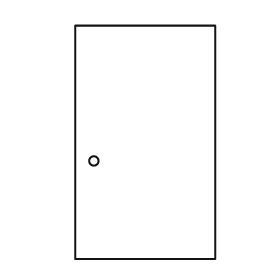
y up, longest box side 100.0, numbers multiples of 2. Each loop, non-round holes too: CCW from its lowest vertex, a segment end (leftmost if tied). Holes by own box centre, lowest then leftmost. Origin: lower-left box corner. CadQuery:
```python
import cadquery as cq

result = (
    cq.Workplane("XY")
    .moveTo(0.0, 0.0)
    .lineTo(60.0, 0.0)
    .lineTo(60.0, 100.0)
    .lineTo(0.0, 100.0)
    .close()
    .moveTo(8.0, 42.0)
    .circle(2.0)
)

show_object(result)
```